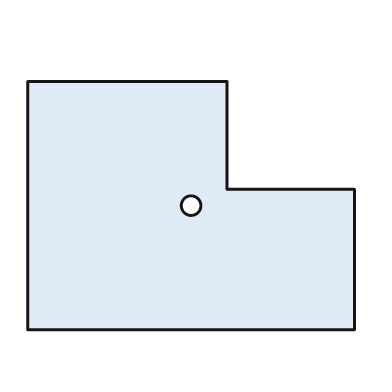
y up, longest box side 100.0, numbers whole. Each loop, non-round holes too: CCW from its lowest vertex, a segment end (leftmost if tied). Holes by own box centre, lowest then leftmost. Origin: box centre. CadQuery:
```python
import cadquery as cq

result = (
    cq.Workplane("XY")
    .moveTo(-50.0, -38.0)
    .lineTo(50.0, -38.0)
    .lineTo(50.0, 5.0)
    .lineTo(11.0, 5.0)
    .lineTo(11.0, 38.0)
    .lineTo(-50.0, 38.0)
    .close()
    .moveTo(0.0, 0.0)
    .circle(3.0)
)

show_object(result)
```